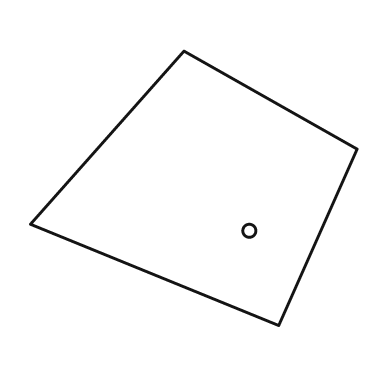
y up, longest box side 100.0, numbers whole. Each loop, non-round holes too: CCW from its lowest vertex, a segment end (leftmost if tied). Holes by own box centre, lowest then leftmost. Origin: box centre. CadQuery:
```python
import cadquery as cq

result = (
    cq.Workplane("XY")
    .moveTo(26.0, -42.0)
    .lineTo(50.0, 12.0)
    .lineTo(-3.0, 42.0)
    .lineTo(-50.0, -11.0)
    .close()
    .moveTo(17.0, -13.0)
    .circle(2.0)
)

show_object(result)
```